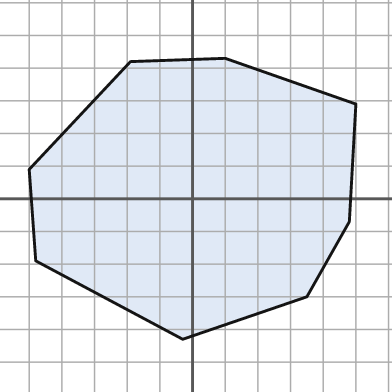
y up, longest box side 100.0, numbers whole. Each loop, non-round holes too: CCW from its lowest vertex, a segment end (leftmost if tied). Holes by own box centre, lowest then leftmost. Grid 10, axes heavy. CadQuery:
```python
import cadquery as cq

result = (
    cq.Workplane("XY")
    .moveTo(-3.0, -43.0)
    .lineTo(35.0, -30.0)
    .lineTo(48.0, -7.0)
    .lineTo(50.0, 29.0)
    .lineTo(10.0, 43.0)
    .lineTo(-19.0, 42.0)
    .lineTo(-50.0, 9.0)
    .lineTo(-48.0, -19.0)
    .close()
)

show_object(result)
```